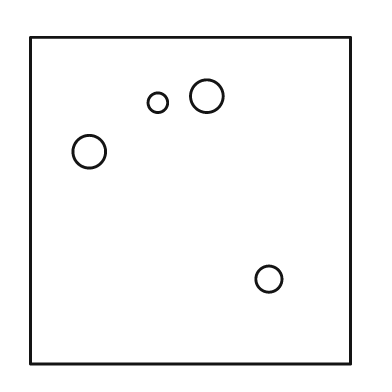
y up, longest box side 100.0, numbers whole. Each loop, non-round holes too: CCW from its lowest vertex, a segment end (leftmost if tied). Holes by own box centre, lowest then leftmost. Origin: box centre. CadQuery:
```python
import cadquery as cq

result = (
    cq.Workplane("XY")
    .moveTo(-49.0, -50.0)
    .lineTo(49.0, -50.0)
    .lineTo(49.0, 50.0)
    .lineTo(-49.0, 50.0)
    .close()
    .moveTo(24.0, -24.0)
    .circle(4.0)
    .moveTo(-31.0, 15.0)
    .circle(5.0)
    .moveTo(-10.0, 30.0)
    .circle(3.0)
    .moveTo(5.0, 32.0)
    .circle(5.0)
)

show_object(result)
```